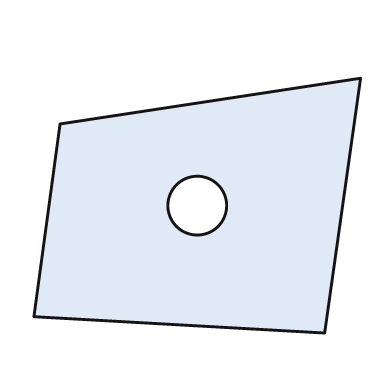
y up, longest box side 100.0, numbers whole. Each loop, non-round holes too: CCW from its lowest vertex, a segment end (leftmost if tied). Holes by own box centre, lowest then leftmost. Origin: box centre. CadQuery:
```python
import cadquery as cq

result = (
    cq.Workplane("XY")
    .moveTo(39.0, -39.0)
    .lineTo(50.0, 39.0)
    .lineTo(-42.0, 25.0)
    .lineTo(-50.0, -34.0)
    .close()
    .moveTo(0.0, 0.0)
    .circle(9.0)
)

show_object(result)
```